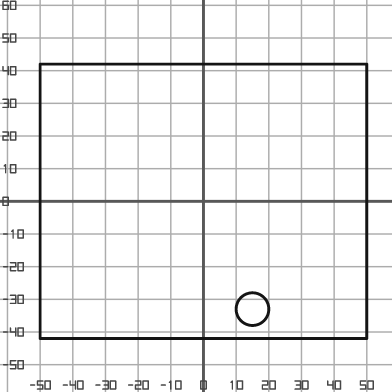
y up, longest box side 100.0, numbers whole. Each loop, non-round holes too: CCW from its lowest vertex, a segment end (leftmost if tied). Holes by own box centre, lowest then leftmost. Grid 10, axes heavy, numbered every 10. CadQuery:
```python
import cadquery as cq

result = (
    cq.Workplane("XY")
    .moveTo(-50.0, -42.0)
    .lineTo(50.0, -42.0)
    .lineTo(50.0, 42.0)
    .lineTo(-50.0, 42.0)
    .close()
    .moveTo(15.0, -33.0)
    .circle(5.0)
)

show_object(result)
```